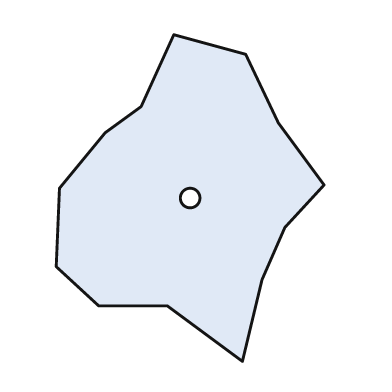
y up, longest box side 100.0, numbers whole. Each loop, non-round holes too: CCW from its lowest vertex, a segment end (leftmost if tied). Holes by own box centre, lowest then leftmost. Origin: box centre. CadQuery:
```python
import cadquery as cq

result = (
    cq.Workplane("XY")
    .moveTo(16.0, -50.0)
    .lineTo(22.0, -25.0)
    .lineTo(29.0, -9.0)
    .lineTo(41.0, 4.0)
    .lineTo(27.0, 23.0)
    .lineTo(17.0, 44.0)
    .lineTo(-5.0, 50.0)
    .lineTo(-15.0, 28.0)
    .lineTo(-26.0, 20.0)
    .lineTo(-40.0, 3.0)
    .lineTo(-41.0, -21.0)
    .lineTo(-28.0, -33.0)
    .lineTo(-7.0, -33.0)
    .close()
    .moveTo(0.0, 0.0)
    .circle(3.0)
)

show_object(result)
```